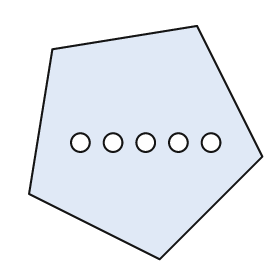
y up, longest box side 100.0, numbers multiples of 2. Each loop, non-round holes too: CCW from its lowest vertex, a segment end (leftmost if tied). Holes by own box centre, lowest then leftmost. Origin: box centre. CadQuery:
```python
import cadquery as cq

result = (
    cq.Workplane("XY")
    .moveTo(6.0, -50.0)
    .lineTo(50.0, -6.0)
    .lineTo(22.0, 50.0)
    .lineTo(-40.0, 40.0)
    .lineTo(-50.0, -22.0)
    .close()
    .moveTo(-28.0, 0.0)
    .circle(4.0)
    .moveTo(-14.0, 0.0)
    .circle(4.0)
    .moveTo(0.0, 0.0)
    .circle(4.0)
    .moveTo(14.0, 0.0)
    .circle(4.0)
    .moveTo(28.0, 0.0)
    .circle(4.0)
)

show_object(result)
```